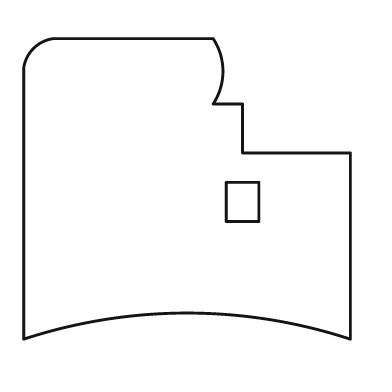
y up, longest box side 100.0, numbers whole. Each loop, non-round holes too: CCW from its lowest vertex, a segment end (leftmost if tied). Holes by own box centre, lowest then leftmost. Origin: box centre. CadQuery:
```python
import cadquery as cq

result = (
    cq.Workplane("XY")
    .moveTo(-50.0, -46.0)
    .threePointArc((0.0, -38.0), (50.0, -46.0))
    .lineTo(50.0, 11.0)
    .lineTo(17.0, 11.0)
    .lineTo(17.0, 26.0)
    .lineTo(8.0, 26.0)
    .threePointArc((11.0, 36.0), (8.0, 46.0))
    .lineTo(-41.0, 46.0)
    .threePointArc((-47.0, 43.0), (-50.0, 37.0))
    .close()
    .moveTo(12.0, -10.0)
    .lineTo(22.0, -10.0)
    .lineTo(22.0, 2.0)
    .lineTo(12.0, 2.0)
    .close()
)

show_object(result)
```